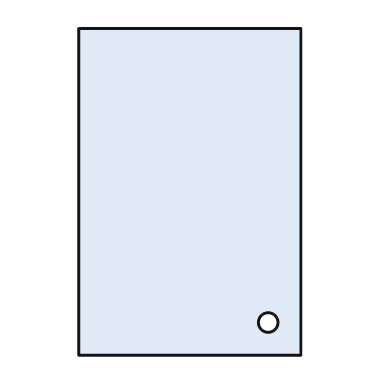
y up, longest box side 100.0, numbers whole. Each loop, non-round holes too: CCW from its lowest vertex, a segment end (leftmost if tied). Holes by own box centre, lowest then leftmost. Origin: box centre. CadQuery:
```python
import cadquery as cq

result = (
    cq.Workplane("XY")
    .moveTo(-34.0, -50.0)
    .lineTo(34.0, -50.0)
    .lineTo(34.0, 50.0)
    .lineTo(-34.0, 50.0)
    .close()
    .moveTo(24.0, -40.0)
    .circle(3.0)
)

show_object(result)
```